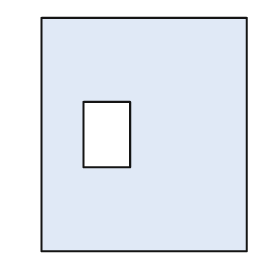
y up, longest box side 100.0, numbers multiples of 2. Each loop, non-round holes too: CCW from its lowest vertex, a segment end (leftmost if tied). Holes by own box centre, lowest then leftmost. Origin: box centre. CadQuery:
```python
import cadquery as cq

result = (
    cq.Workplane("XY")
    .moveTo(-44.0, -50.0)
    .lineTo(44.0, -50.0)
    .lineTo(44.0, 50.0)
    .lineTo(-44.0, 50.0)
    .close()
    .moveTo(-26.0, -14.0)
    .lineTo(-6.0, -14.0)
    .lineTo(-6.0, 14.0)
    .lineTo(-26.0, 14.0)
    .close()
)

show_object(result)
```